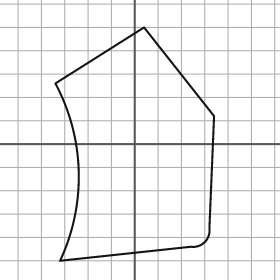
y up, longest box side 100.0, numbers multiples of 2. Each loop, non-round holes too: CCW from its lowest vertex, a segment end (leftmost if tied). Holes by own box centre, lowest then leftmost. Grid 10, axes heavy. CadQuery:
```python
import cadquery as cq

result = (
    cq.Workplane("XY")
    .moveTo(-32.0, -50.0)
    .lineTo(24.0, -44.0)
    .threePointArc((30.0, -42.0), (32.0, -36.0))
    .lineTo(34.0, 12.0)
    .lineTo(4.0, 50.0)
    .lineTo(-34.0, 26.0)
    .threePointArc((-24.0, -12.0), (-32.0, -50.0))
    .close()
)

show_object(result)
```